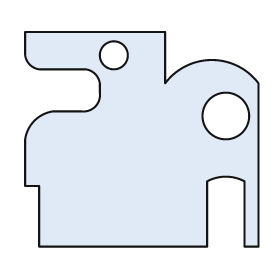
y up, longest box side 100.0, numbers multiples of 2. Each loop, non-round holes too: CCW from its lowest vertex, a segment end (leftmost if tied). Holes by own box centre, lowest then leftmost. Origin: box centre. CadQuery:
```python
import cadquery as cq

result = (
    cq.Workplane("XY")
    .moveTo(-44.0, -46.0)
    .lineTo(28.0, -46.0)
    .lineTo(28.0, -18.0)
    .threePointArc((36.0, -16.0), (44.0, -18.0))
    .lineTo(44.0, -46.0)
    .lineTo(50.0, -46.0)
    .lineTo(50.0, 24.0)
    .threePointArc((30.0, 34.0), (10.0, 24.0))
    .lineTo(10.0, 46.0)
    .lineTo(-50.0, 46.0)
    .lineTo(-50.0, 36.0)
    .threePointArc((-48.0, 32.0), (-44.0, 30.0))
    .lineTo(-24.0, 30.0)
    .threePointArc((-20.0, 28.0), (-18.0, 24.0))
    .lineTo(-18.0, 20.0)
    .threePointArc((-20.0, 14.0), (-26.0, 12.0))
    .lineTo(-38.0, 12.0)
    .threePointArc((-46.0, 8.0), (-50.0, 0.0))
    .lineTo(-50.0, -20.0)
    .lineTo(-44.0, -20.0)
    .close()
    .moveTo(36.0, 10.0)
    .circle(10.0)
    .moveTo(-12.0, 36.0)
    .circle(6.0)
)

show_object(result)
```